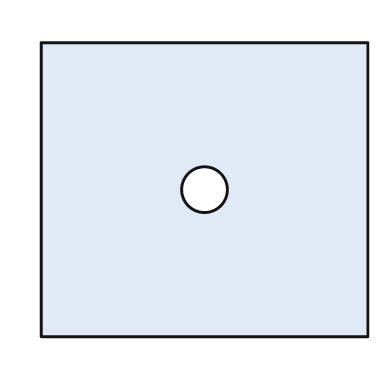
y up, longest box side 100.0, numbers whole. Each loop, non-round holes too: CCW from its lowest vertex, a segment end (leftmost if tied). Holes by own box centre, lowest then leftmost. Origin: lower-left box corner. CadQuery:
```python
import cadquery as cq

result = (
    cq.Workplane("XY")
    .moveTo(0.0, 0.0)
    .lineTo(100.0, 0.0)
    .lineTo(100.0, 90.0)
    .lineTo(0.0, 90.0)
    .close()
    .moveTo(50.0, 45.0)
    .circle(7.0)
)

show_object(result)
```